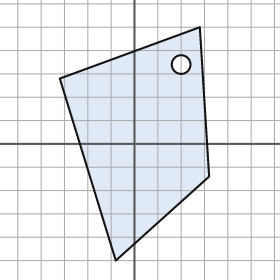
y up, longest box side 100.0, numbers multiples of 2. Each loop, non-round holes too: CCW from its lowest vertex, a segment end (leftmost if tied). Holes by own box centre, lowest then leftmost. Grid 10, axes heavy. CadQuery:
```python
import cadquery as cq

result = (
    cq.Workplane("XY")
    .moveTo(-8.0, -50.0)
    .lineTo(32.0, -14.0)
    .lineTo(28.0, 50.0)
    .lineTo(-32.0, 28.0)
    .close()
    .moveTo(20.0, 34.0)
    .circle(4.0)
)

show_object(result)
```